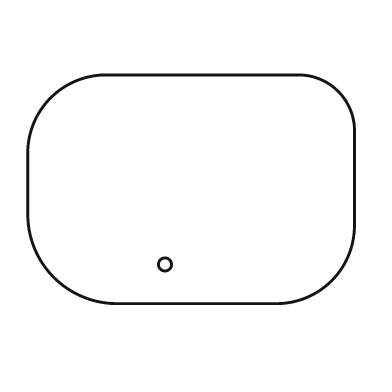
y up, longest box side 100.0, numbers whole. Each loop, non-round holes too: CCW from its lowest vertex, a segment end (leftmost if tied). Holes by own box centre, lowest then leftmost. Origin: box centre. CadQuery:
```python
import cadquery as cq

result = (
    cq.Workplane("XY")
    .moveTo(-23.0, -35.0)
    .lineTo(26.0, -35.0)
    .threePointArc((43.0, -28.0), (50.0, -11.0))
    .lineTo(50.0, 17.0)
    .threePointArc((45.0, 30.0), (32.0, 35.0))
    .lineTo(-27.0, 35.0)
    .threePointArc((-43.0, 28.0), (-50.0, 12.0))
    .lineTo(-50.0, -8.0)
    .threePointArc((-42.0, -27.0), (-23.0, -35.0))
    .close()
    .moveTo(-8.0, -23.0)
    .circle(2.0)
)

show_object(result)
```